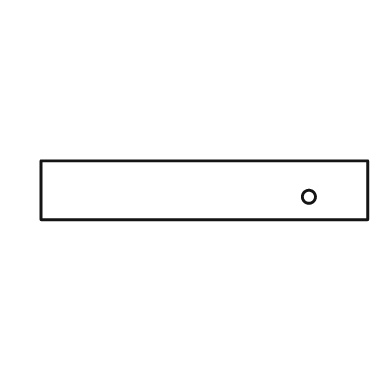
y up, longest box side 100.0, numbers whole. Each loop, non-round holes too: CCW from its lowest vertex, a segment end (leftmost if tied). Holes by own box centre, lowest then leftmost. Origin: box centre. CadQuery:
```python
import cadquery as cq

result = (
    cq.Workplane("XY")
    .moveTo(-50.0, -9.0)
    .lineTo(50.0, -9.0)
    .lineTo(50.0, 9.0)
    .lineTo(-50.0, 9.0)
    .close()
    .moveTo(32.0, -2.0)
    .circle(2.0)
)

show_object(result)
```